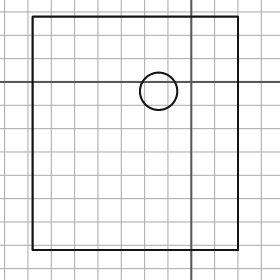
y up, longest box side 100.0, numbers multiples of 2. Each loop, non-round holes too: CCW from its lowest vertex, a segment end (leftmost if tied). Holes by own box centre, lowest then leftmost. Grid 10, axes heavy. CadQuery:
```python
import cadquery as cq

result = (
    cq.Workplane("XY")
    .moveTo(-68.0, -72.0)
    .lineTo(20.0, -72.0)
    .lineTo(20.0, 28.0)
    .lineTo(-68.0, 28.0)
    .close()
    .moveTo(-14.0, -4.0)
    .circle(8.0)
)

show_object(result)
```